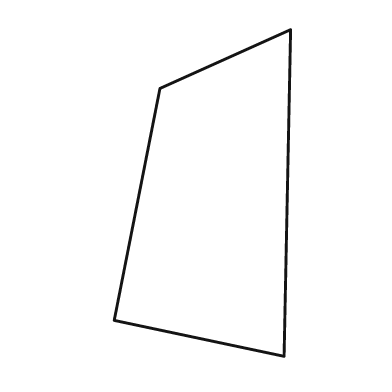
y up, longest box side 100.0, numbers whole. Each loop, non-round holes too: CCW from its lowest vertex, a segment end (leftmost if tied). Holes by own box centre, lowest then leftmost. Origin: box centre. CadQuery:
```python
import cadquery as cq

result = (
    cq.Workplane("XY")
    .moveTo(25.0, -50.0)
    .lineTo(27.0, 50.0)
    .lineTo(-13.0, 32.0)
    .lineTo(-27.0, -39.0)
    .close()
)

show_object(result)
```